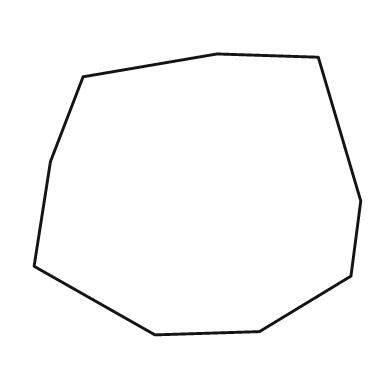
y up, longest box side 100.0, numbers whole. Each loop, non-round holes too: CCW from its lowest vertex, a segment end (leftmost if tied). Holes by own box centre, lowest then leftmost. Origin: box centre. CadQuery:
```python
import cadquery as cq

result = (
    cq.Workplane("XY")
    .moveTo(-13.0, -43.0)
    .lineTo(19.0, -42.0)
    .lineTo(47.0, -25.0)
    .lineTo(50.0, -2.0)
    .lineTo(37.0, 42.0)
    .lineTo(6.0, 43.0)
    .lineTo(-35.0, 36.0)
    .lineTo(-45.0, 10.0)
    .lineTo(-50.0, -22.0)
    .close()
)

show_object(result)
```